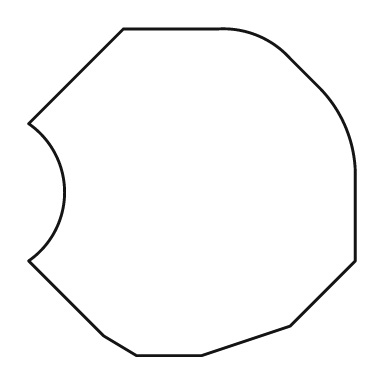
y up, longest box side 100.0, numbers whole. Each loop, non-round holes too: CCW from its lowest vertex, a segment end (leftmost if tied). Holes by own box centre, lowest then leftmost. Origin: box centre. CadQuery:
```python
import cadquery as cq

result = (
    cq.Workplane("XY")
    .moveTo(-17.0, -50.0)
    .lineTo(3.0, -50.0)
    .lineTo(30.0, -41.0)
    .lineTo(50.0, -21.0)
    .lineTo(50.0, 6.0)
    .threePointArc((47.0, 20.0), (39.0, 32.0))
    .lineTo(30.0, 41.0)
    .threePointArc((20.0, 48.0), (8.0, 50.0))
    .lineTo(-21.0, 50.0)
    .lineTo(-50.0, 21.0)
    .threePointArc((-39.0, 0.0), (-50.0, -21.0))
    .lineTo(-27.0, -44.0)
    .close()
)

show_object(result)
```